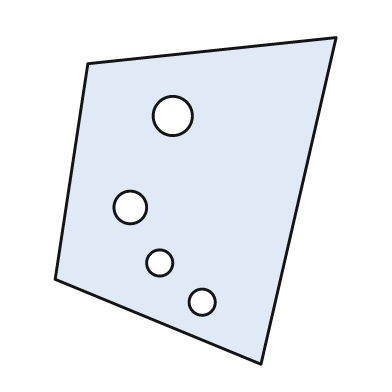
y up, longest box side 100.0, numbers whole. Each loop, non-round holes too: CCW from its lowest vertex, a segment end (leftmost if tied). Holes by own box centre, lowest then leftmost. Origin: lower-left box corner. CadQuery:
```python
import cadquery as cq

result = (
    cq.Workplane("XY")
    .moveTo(63.0, 0.0)
    .lineTo(86.0, 100.0)
    .lineTo(10.0, 92.0)
    .lineTo(0.0, 26.0)
    .close()
    .moveTo(45.0, 19.0)
    .circle(4.0)
    .moveTo(32.0, 31.0)
    .circle(4.0)
    .moveTo(23.0, 48.0)
    .circle(5.0)
    .moveTo(36.0, 76.0)
    .circle(6.0)
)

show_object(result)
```